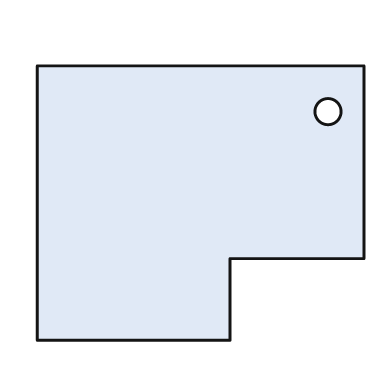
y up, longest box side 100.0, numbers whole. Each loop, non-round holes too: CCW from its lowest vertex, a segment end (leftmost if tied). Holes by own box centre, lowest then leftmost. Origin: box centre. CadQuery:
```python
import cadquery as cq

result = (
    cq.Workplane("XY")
    .moveTo(-50.0, -42.0)
    .lineTo(9.0, -42.0)
    .lineTo(9.0, -17.0)
    .lineTo(50.0, -17.0)
    .lineTo(50.0, 42.0)
    .lineTo(-50.0, 42.0)
    .close()
    .moveTo(39.0, 28.0)
    .circle(4.0)
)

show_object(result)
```